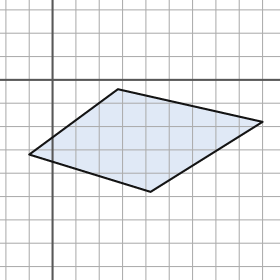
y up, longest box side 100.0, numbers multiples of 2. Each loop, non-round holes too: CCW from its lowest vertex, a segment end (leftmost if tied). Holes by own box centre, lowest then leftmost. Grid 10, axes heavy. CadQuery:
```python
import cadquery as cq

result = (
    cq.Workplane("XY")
    .moveTo(42.0, -48.0)
    .lineTo(90.0, -18.0)
    .lineTo(28.0, -4.0)
    .lineTo(-10.0, -32.0)
    .close()
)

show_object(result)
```